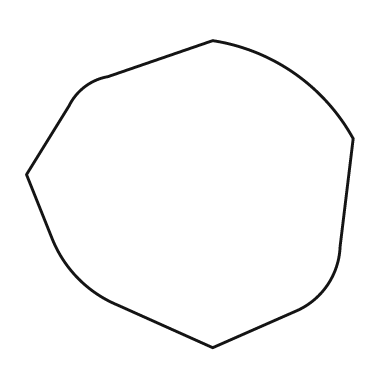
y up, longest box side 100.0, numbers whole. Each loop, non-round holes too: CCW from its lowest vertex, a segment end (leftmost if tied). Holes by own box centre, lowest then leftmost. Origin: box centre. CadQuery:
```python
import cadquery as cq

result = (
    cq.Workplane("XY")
    .moveTo(7.0, -47.0)
    .lineTo(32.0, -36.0)
    .threePointArc((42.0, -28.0), (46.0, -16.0))
    .lineTo(50.0, 17.0)
    .threePointArc((32.0, 37.0), (7.0, 47.0))
    .lineTo(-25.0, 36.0)
    .threePointArc((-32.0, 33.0), (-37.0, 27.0))
    .lineTo(-50.0, 6.0)
    .lineTo(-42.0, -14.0)
    .threePointArc((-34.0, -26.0), (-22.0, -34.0))
    .close()
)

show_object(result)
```